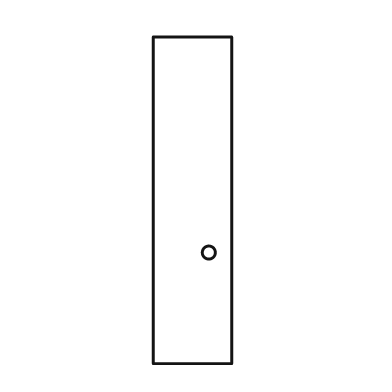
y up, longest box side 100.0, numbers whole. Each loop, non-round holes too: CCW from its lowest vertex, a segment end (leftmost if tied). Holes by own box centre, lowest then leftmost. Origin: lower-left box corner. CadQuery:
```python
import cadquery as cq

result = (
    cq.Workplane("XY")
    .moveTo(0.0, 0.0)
    .lineTo(24.0, 0.0)
    .lineTo(24.0, 100.0)
    .lineTo(0.0, 100.0)
    .close()
    .moveTo(17.0, 34.0)
    .circle(2.0)
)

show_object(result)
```